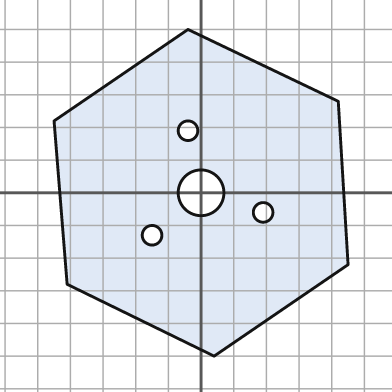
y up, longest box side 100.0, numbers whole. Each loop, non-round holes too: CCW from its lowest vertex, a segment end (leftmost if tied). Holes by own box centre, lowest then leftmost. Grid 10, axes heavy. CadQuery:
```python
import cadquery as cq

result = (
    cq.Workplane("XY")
    .moveTo(4.0, -50.0)
    .lineTo(45.0, -22.0)
    .lineTo(42.0, 28.0)
    .lineTo(-4.0, 50.0)
    .lineTo(-45.0, 22.0)
    .lineTo(-41.0, -28.0)
    .close()
    .moveTo(-15.0, -13.0)
    .circle(3.0)
    .moveTo(19.0, -6.0)
    .circle(3.0)
    .moveTo(0.0, 0.0)
    .circle(7.0)
    .moveTo(-4.0, 19.0)
    .circle(3.0)
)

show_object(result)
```